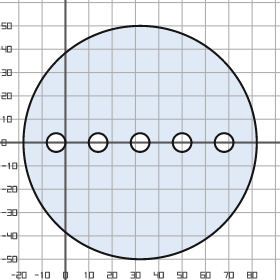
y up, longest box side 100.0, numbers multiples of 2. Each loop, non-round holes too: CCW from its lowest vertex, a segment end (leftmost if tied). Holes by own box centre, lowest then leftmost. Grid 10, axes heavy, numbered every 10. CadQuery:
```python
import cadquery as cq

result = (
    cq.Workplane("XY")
    .moveTo(32.0, 0.0)
    .circle(50.0)
    .moveTo(-4.0, 0.0)
    .circle(4.0)
    .moveTo(14.0, 0.0)
    .circle(4.0)
    .moveTo(32.0, 0.0)
    .circle(4.0)
    .moveTo(50.0, 0.0)
    .circle(4.0)
    .moveTo(68.0, 0.0)
    .circle(4.0)
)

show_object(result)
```